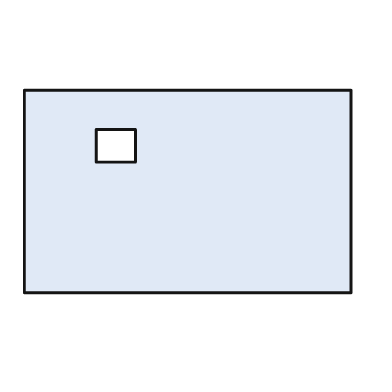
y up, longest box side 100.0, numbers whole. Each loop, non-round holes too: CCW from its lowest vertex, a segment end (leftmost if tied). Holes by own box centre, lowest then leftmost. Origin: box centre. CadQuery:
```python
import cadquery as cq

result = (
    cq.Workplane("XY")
    .moveTo(-50.0, -31.0)
    .lineTo(50.0, -31.0)
    .lineTo(50.0, 31.0)
    .lineTo(-50.0, 31.0)
    .close()
    .moveTo(-28.0, 9.0)
    .lineTo(-16.0, 9.0)
    .lineTo(-16.0, 19.0)
    .lineTo(-28.0, 19.0)
    .close()
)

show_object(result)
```